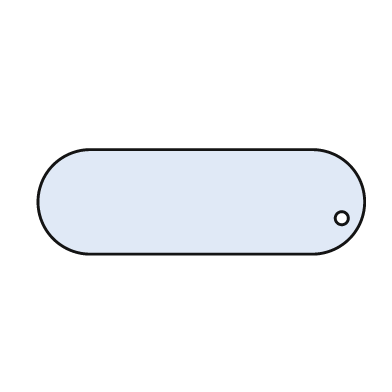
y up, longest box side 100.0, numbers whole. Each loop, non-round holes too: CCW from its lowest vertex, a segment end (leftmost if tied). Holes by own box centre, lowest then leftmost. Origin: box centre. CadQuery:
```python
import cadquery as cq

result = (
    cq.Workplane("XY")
    .moveTo(-34.0, -16.0)
    .lineTo(34.0, -16.0)
    .threePointArc((50.0, 0.0), (34.0, 16.0))
    .lineTo(-34.0, 16.0)
    .threePointArc((-50.0, 0.0), (-34.0, -16.0))
    .close()
    .moveTo(43.0, -5.0)
    .circle(2.0)
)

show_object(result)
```